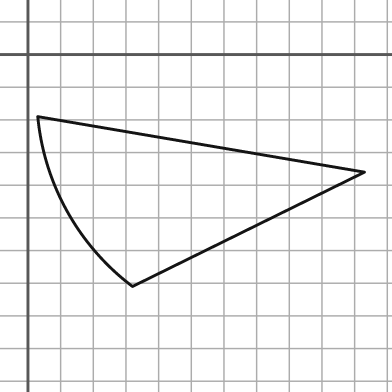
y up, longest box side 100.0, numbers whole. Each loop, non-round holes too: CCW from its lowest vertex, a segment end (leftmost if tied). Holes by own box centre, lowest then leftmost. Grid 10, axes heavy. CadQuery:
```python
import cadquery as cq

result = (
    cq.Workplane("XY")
    .moveTo(32.0, -71.0)
    .lineTo(103.0, -36.0)
    .lineTo(3.0, -19.0)
    .threePointArc((12.0, -48.0), (32.0, -71.0))
    .close()
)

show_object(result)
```